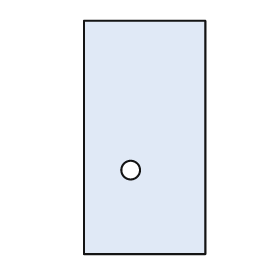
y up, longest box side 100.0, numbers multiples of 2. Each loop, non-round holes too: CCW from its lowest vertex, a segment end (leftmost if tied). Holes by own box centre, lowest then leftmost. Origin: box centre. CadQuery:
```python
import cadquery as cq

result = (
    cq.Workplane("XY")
    .moveTo(-26.0, -50.0)
    .lineTo(26.0, -50.0)
    .lineTo(26.0, 50.0)
    .lineTo(-26.0, 50.0)
    .close()
    .moveTo(-6.0, -14.0)
    .circle(4.0)
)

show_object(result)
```